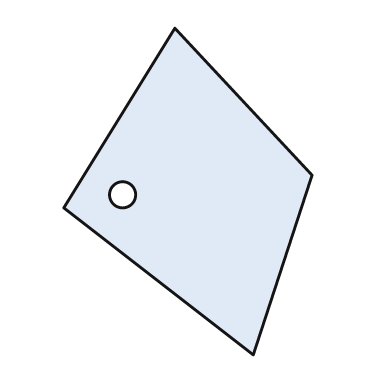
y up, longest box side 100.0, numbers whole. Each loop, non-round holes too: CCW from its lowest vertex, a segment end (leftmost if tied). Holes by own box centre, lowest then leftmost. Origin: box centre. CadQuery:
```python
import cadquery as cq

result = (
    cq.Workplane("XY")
    .moveTo(20.0, -50.0)
    .lineTo(38.0, 5.0)
    .lineTo(-4.0, 50.0)
    .lineTo(-38.0, -5.0)
    .close()
    .moveTo(-20.0, -1.0)
    .circle(4.0)
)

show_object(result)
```